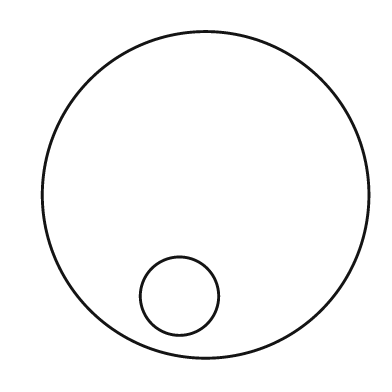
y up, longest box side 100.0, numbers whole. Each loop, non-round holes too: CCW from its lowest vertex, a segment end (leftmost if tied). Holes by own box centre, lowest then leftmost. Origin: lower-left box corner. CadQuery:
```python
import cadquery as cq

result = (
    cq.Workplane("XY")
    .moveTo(50.0, 50.0)
    .circle(50.0)
    .moveTo(42.0, 19.0)
    .circle(12.0)
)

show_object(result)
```